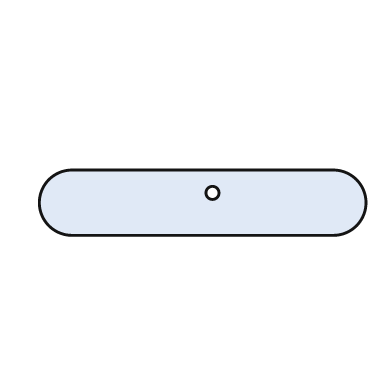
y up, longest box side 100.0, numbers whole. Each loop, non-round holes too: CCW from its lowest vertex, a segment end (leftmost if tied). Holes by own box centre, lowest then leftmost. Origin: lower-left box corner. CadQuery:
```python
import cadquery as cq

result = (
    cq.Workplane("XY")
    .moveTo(10.0, 0.0)
    .lineTo(90.0, 0.0)
    .threePointArc((100.0, 10.0), (90.0, 20.0))
    .lineTo(10.0, 20.0)
    .threePointArc((0.0, 10.0), (10.0, 0.0))
    .close()
    .moveTo(53.0, 13.0)
    .circle(2.0)
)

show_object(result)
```